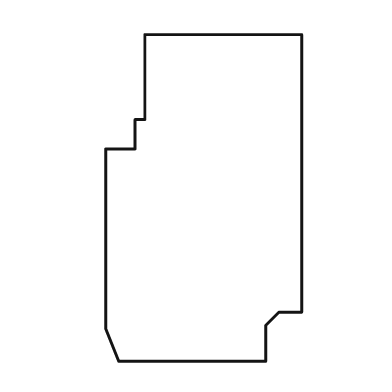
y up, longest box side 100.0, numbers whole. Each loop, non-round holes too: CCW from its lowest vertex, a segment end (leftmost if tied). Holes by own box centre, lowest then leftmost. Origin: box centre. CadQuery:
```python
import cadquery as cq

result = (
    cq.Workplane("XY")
    .moveTo(-26.0, -50.0)
    .lineTo(19.0, -50.0)
    .lineTo(19.0, -39.0)
    .lineTo(23.0, -35.0)
    .lineTo(30.0, -35.0)
    .lineTo(30.0, 50.0)
    .lineTo(-18.0, 50.0)
    .lineTo(-18.0, 24.0)
    .lineTo(-21.0, 24.0)
    .lineTo(-21.0, 15.0)
    .lineTo(-30.0, 15.0)
    .lineTo(-30.0, -40.0)
    .close()
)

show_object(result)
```